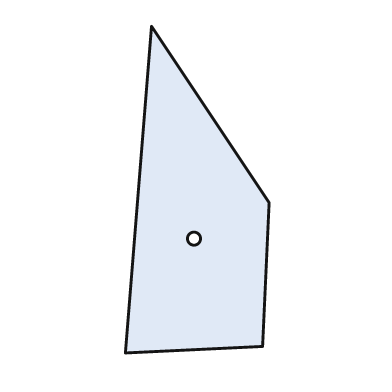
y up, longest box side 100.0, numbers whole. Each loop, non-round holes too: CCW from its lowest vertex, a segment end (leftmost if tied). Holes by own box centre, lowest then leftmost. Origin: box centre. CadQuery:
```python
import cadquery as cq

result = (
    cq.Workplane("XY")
    .moveTo(-22.0, -50.0)
    .lineTo(20.0, -48.0)
    .lineTo(22.0, -4.0)
    .lineTo(-14.0, 50.0)
    .close()
    .moveTo(-1.0, -15.0)
    .circle(2.0)
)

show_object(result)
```